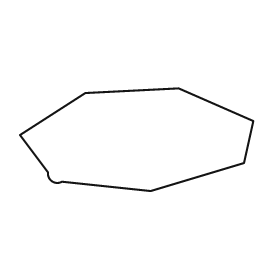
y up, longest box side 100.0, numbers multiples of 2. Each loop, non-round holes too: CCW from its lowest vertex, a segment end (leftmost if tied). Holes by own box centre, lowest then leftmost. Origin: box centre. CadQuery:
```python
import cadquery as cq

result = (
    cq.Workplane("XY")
    .moveTo(6.0, -22.0)
    .lineTo(46.0, -10.0)
    .lineTo(50.0, 8.0)
    .lineTo(18.0, 22.0)
    .lineTo(-22.0, 20.0)
    .lineTo(-50.0, 2.0)
    .lineTo(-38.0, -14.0)
    .threePointArc((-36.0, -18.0), (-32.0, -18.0))
    .close()
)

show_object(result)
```